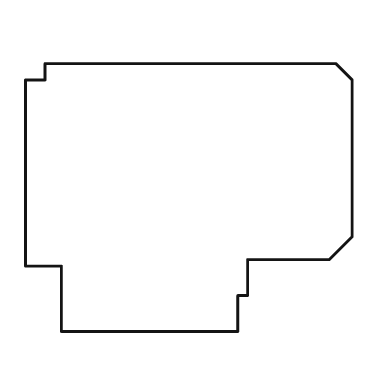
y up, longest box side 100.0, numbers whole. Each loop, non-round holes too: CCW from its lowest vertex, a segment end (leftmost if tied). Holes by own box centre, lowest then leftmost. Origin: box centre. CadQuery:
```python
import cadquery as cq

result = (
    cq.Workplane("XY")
    .moveTo(-39.0, -41.0)
    .lineTo(15.0, -41.0)
    .lineTo(15.0, -30.0)
    .lineTo(18.0, -30.0)
    .lineTo(18.0, -19.0)
    .lineTo(43.0, -19.0)
    .lineTo(50.0, -12.0)
    .lineTo(50.0, 36.0)
    .lineTo(45.0, 41.0)
    .lineTo(-44.0, 41.0)
    .lineTo(-44.0, 36.0)
    .lineTo(-50.0, 36.0)
    .lineTo(-50.0, -21.0)
    .lineTo(-39.0, -21.0)
    .close()
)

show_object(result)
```